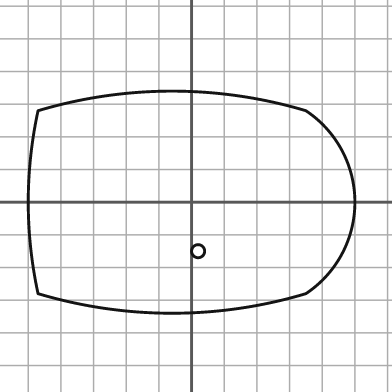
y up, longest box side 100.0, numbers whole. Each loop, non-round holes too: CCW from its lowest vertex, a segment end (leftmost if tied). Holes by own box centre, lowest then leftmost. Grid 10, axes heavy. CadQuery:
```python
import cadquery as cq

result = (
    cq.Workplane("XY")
    .moveTo(-47.0, -28.0)
    .threePointArc((-6.0, -34.0), (35.0, -28.0))
    .threePointArc((50.0, 0.0), (35.0, 28.0))
    .threePointArc((-6.0, 34.0), (-47.0, 28.0))
    .threePointArc((-50.0, 0.0), (-47.0, -28.0))
    .close()
    .moveTo(2.0, -15.0)
    .circle(2.0)
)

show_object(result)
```